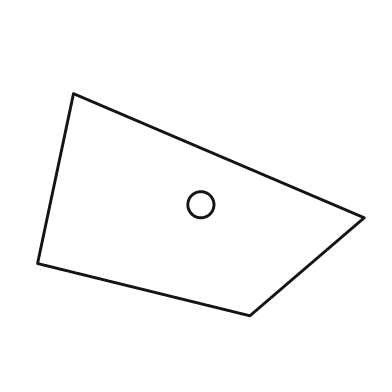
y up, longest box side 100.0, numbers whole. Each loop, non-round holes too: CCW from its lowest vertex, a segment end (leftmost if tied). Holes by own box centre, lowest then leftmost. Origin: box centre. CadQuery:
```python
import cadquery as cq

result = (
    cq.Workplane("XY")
    .moveTo(15.0, -34.0)
    .lineTo(50.0, -4.0)
    .lineTo(-39.0, 34.0)
    .lineTo(-50.0, -18.0)
    .close()
    .moveTo(0.0, 0.0)
    .circle(4.0)
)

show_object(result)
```